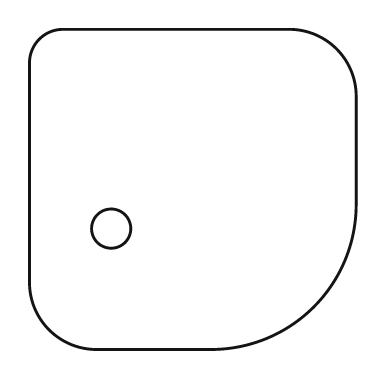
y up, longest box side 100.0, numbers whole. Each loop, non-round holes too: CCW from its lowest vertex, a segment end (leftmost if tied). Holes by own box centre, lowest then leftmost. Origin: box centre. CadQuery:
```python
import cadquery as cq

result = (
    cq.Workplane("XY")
    .moveTo(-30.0, -49.0)
    .lineTo(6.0, -49.0)
    .threePointArc((37.0, -36.0), (50.0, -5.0))
    .lineTo(50.0, 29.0)
    .threePointArc((44.0, 43.0), (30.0, 49.0))
    .lineTo(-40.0, 49.0)
    .threePointArc((-47.0, 46.0), (-50.0, 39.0))
    .lineTo(-50.0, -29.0)
    .threePointArc((-44.0, -43.0), (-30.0, -49.0))
    .close()
    .moveTo(-25.0, -12.0)
    .circle(6.0)
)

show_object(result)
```